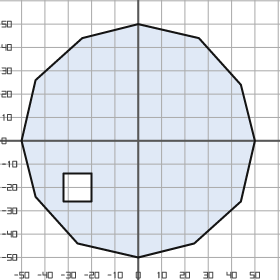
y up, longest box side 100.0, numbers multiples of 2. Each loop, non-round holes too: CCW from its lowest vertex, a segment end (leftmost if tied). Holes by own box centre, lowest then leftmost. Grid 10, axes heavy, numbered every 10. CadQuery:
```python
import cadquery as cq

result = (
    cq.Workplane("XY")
    .moveTo(0.0, -50.0)
    .lineTo(24.0, -44.0)
    .lineTo(44.0, -26.0)
    .lineTo(50.0, 0.0)
    .lineTo(44.0, 24.0)
    .lineTo(26.0, 44.0)
    .lineTo(0.0, 50.0)
    .lineTo(-24.0, 44.0)
    .lineTo(-44.0, 26.0)
    .lineTo(-50.0, 0.0)
    .lineTo(-44.0, -24.0)
    .lineTo(-26.0, -44.0)
    .close()
    .moveTo(-32.0, -26.0)
    .lineTo(-20.0, -26.0)
    .lineTo(-20.0, -14.0)
    .lineTo(-32.0, -14.0)
    .close()
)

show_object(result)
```